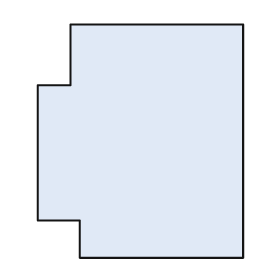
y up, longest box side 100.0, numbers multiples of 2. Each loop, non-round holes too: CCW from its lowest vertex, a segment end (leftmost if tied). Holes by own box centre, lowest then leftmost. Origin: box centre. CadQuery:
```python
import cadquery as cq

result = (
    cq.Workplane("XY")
    .moveTo(-26.0, -50.0)
    .lineTo(44.0, -50.0)
    .lineTo(44.0, 50.0)
    .lineTo(-30.0, 50.0)
    .lineTo(-30.0, 24.0)
    .lineTo(-44.0, 24.0)
    .lineTo(-44.0, -34.0)
    .lineTo(-26.0, -34.0)
    .close()
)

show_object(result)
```